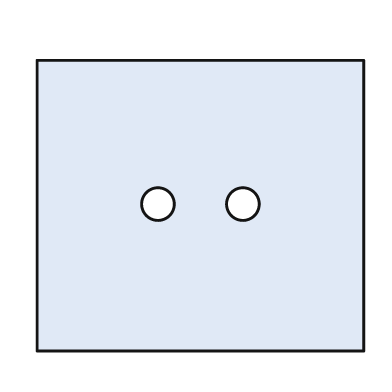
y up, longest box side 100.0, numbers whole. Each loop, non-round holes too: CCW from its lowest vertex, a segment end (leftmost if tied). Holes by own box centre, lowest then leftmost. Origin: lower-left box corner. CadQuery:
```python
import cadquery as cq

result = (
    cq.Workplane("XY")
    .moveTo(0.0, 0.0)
    .lineTo(100.0, 0.0)
    .lineTo(100.0, 89.0)
    .lineTo(0.0, 89.0)
    .close()
    .moveTo(37.0, 45.0)
    .circle(5.0)
    .moveTo(63.0, 45.0)
    .circle(5.0)
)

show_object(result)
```